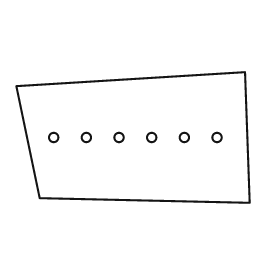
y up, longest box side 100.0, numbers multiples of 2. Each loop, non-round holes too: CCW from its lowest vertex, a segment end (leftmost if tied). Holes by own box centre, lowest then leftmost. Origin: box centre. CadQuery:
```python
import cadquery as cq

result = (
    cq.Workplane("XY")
    .moveTo(50.0, -28.0)
    .lineTo(48.0, 28.0)
    .lineTo(-50.0, 22.0)
    .lineTo(-40.0, -26.0)
    .close()
    .moveTo(-34.0, 0.0)
    .circle(2.0)
    .moveTo(-20.0, 0.0)
    .circle(2.0)
    .moveTo(-6.0, 0.0)
    .circle(2.0)
    .moveTo(8.0, 0.0)
    .circle(2.0)
    .moveTo(22.0, 0.0)
    .circle(2.0)
    .moveTo(36.0, 0.0)
    .circle(2.0)
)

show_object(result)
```